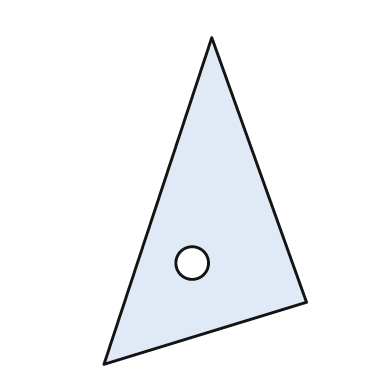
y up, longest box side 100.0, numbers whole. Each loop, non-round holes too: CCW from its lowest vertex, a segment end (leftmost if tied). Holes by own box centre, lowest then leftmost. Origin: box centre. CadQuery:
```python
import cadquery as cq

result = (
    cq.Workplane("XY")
    .moveTo(-31.0, -50.0)
    .lineTo(31.0, -31.0)
    .lineTo(2.0, 50.0)
    .close()
    .moveTo(-4.0, -19.0)
    .circle(5.0)
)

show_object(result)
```